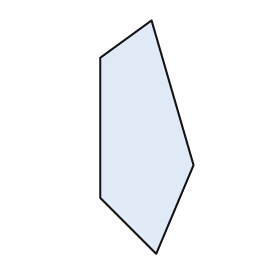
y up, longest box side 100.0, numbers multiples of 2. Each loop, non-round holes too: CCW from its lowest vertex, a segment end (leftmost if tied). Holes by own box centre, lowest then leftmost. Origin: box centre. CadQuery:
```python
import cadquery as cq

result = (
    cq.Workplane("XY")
    .moveTo(4.0, -50.0)
    .lineTo(20.0, -12.0)
    .lineTo(2.0, 50.0)
    .lineTo(-20.0, 34.0)
    .lineTo(-20.0, -26.0)
    .close()
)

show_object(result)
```